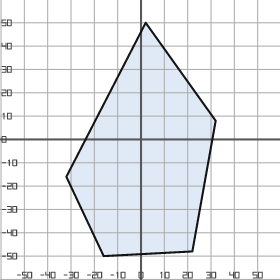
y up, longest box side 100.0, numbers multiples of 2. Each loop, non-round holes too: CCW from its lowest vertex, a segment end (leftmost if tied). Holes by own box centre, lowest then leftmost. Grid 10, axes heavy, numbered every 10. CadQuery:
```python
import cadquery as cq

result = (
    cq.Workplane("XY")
    .moveTo(-16.0, -50.0)
    .lineTo(22.0, -48.0)
    .lineTo(32.0, 8.0)
    .lineTo(2.0, 50.0)
    .lineTo(-32.0, -16.0)
    .close()
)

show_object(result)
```